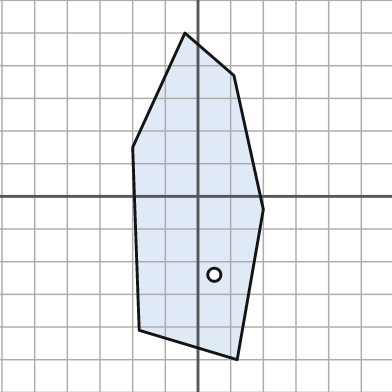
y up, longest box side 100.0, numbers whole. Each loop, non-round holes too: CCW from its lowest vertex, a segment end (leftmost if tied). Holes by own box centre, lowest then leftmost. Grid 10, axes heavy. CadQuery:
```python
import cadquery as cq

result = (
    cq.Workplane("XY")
    .moveTo(12.0, -50.0)
    .lineTo(20.0, -4.0)
    .lineTo(11.0, 37.0)
    .lineTo(-4.0, 50.0)
    .lineTo(-20.0, 15.0)
    .lineTo(-18.0, -41.0)
    .close()
    .moveTo(5.0, -24.0)
    .circle(2.0)
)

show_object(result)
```